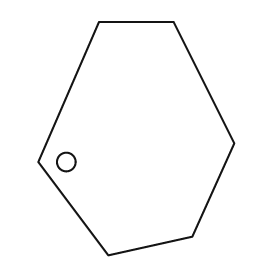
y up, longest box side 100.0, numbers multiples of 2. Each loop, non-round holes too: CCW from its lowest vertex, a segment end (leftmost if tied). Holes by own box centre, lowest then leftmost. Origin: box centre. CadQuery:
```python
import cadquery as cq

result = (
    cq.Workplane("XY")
    .moveTo(-12.0, -50.0)
    .lineTo(24.0, -42.0)
    .lineTo(42.0, -2.0)
    .lineTo(16.0, 50.0)
    .lineTo(-16.0, 50.0)
    .lineTo(-42.0, -10.0)
    .close()
    .moveTo(-30.0, -10.0)
    .circle(4.0)
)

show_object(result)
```